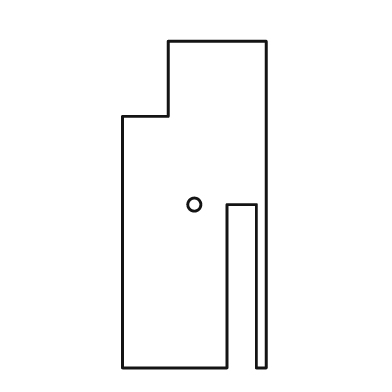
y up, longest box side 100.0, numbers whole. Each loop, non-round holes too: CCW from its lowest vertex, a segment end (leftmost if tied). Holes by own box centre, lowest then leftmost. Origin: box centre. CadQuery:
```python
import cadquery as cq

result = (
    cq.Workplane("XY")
    .moveTo(-22.0, -50.0)
    .lineTo(10.0, -50.0)
    .lineTo(10.0, 0.0)
    .lineTo(19.0, 0.0)
    .lineTo(19.0, -50.0)
    .lineTo(22.0, -50.0)
    .lineTo(22.0, 50.0)
    .lineTo(-8.0, 50.0)
    .lineTo(-8.0, 27.0)
    .lineTo(-22.0, 27.0)
    .close()
    .moveTo(0.0, 0.0)
    .circle(2.0)
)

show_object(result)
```